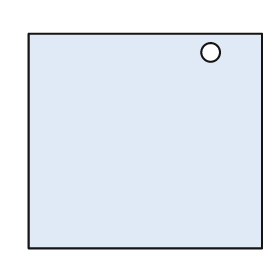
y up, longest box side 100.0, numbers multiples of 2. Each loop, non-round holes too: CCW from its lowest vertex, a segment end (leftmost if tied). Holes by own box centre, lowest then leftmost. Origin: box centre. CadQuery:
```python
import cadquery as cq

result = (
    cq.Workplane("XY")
    .moveTo(-50.0, -46.0)
    .lineTo(50.0, -46.0)
    .lineTo(50.0, 46.0)
    .lineTo(-50.0, 46.0)
    .close()
    .moveTo(28.0, 38.0)
    .circle(4.0)
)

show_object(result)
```